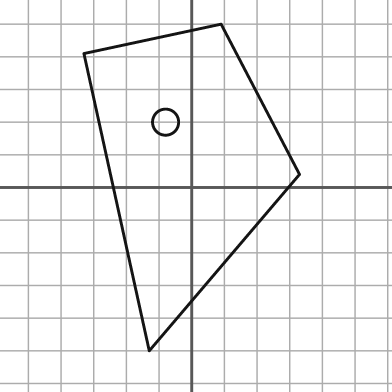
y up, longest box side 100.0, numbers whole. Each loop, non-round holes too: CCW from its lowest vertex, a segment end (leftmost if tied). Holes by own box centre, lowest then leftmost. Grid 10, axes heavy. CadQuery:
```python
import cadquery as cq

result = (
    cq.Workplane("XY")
    .moveTo(-13.0, -50.0)
    .lineTo(33.0, 4.0)
    .lineTo(9.0, 50.0)
    .lineTo(-33.0, 41.0)
    .close()
    .moveTo(-8.0, 20.0)
    .circle(4.0)
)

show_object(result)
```